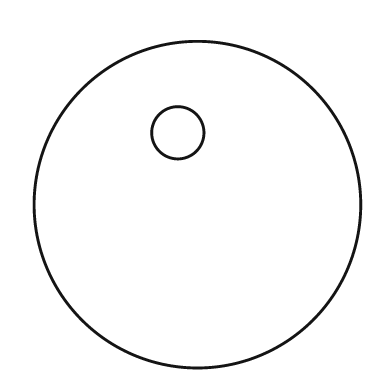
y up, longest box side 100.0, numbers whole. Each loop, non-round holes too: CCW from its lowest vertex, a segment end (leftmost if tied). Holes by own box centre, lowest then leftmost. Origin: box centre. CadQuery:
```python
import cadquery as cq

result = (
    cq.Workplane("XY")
    .moveTo(0.0, 0.0)
    .circle(50.0)
    .moveTo(-6.0, 22.0)
    .circle(8.0)
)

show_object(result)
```